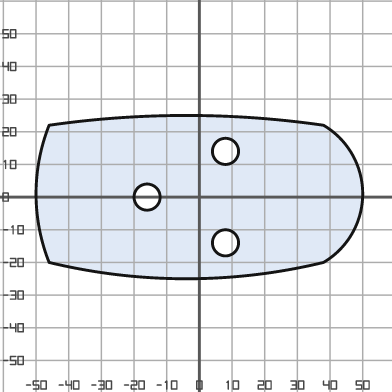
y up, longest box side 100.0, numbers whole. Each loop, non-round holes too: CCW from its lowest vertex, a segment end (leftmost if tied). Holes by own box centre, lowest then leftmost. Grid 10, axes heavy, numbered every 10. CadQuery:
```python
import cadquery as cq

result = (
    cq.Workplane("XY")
    .moveTo(-46.0, -20.0)
    .threePointArc((-4.0, -25.0), (38.0, -20.0))
    .threePointArc((50.0, 1.0), (38.0, 22.0))
    .threePointArc((-4.0, 25.0), (-46.0, 22.0))
    .threePointArc((-50.0, 1.0), (-46.0, -20.0))
    .close()
    .moveTo(8.0, -14.0)
    .circle(4.0)
    .moveTo(-16.0, 0.0)
    .circle(4.0)
    .moveTo(8.0, 14.0)
    .circle(4.0)
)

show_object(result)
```